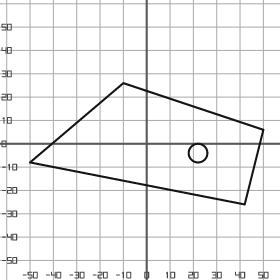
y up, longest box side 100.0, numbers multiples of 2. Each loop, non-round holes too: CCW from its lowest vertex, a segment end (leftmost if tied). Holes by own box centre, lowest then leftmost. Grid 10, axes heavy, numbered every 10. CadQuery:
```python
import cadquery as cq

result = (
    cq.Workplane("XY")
    .moveTo(42.0, -26.0)
    .lineTo(50.0, 6.0)
    .lineTo(-10.0, 26.0)
    .lineTo(-50.0, -8.0)
    .close()
    .moveTo(22.0, -4.0)
    .circle(4.0)
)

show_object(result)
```